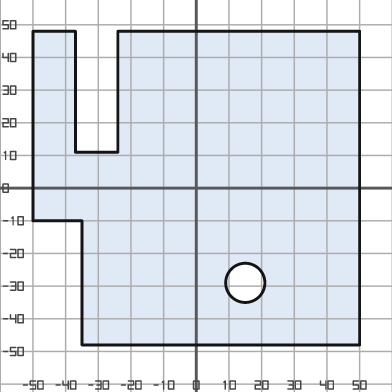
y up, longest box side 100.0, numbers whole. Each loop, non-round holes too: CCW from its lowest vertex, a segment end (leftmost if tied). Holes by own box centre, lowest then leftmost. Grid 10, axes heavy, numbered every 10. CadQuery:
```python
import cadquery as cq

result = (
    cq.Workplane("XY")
    .moveTo(-35.0, -48.0)
    .lineTo(50.0, -48.0)
    .lineTo(50.0, 48.0)
    .lineTo(-24.0, 48.0)
    .lineTo(-24.0, 11.0)
    .lineTo(-37.0, 11.0)
    .lineTo(-37.0, 48.0)
    .lineTo(-50.0, 48.0)
    .lineTo(-50.0, -10.0)
    .lineTo(-35.0, -10.0)
    .close()
    .moveTo(15.0, -29.0)
    .circle(6.0)
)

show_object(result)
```